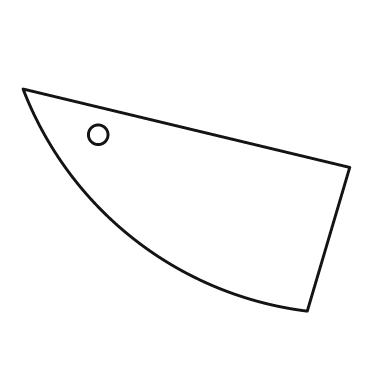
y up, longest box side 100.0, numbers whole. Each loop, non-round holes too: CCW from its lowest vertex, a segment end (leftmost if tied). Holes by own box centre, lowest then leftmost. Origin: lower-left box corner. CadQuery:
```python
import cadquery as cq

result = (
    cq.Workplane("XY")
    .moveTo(87.0, 0.0)
    .lineTo(100.0, 44.0)
    .lineTo(0.0, 68.0)
    .threePointArc((34.0, 22.0), (87.0, 0.0))
    .close()
    .moveTo(23.0, 54.0)
    .circle(3.0)
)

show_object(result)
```